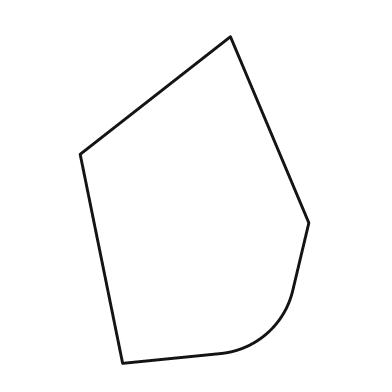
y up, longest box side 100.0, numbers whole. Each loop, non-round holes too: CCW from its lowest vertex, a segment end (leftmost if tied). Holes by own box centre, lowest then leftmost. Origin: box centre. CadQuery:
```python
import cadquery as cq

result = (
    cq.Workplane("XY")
    .moveTo(-22.0, -50.0)
    .lineTo(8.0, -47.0)
    .threePointArc((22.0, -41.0), (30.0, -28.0))
    .lineTo(35.0, -7.0)
    .lineTo(11.0, 50.0)
    .lineTo(-35.0, 14.0)
    .close()
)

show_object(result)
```